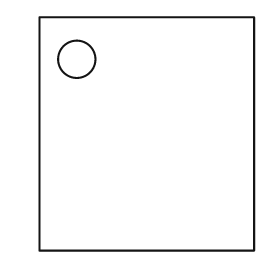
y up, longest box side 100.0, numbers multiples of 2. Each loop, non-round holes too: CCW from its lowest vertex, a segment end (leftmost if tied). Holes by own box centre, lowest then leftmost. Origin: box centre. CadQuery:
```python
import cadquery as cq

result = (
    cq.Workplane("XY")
    .moveTo(-46.0, -50.0)
    .lineTo(46.0, -50.0)
    .lineTo(46.0, 50.0)
    .lineTo(-46.0, 50.0)
    .close()
    .moveTo(-30.0, 32.0)
    .circle(8.0)
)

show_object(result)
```